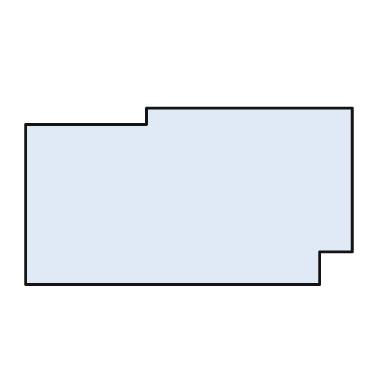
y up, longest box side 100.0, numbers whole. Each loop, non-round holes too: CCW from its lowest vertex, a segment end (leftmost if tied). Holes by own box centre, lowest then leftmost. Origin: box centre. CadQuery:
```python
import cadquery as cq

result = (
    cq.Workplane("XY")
    .moveTo(-50.0, -27.0)
    .lineTo(40.0, -27.0)
    .lineTo(40.0, -17.0)
    .lineTo(50.0, -17.0)
    .lineTo(50.0, 27.0)
    .lineTo(-13.0, 27.0)
    .lineTo(-13.0, 22.0)
    .lineTo(-50.0, 22.0)
    .close()
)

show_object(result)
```